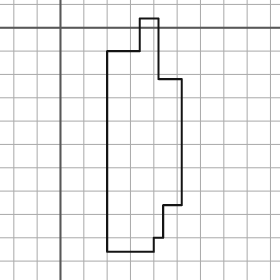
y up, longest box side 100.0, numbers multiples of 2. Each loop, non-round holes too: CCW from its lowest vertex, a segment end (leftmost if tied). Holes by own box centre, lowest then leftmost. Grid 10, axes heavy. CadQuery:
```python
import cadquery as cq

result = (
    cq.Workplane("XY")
    .moveTo(20.0, -96.0)
    .lineTo(40.0, -96.0)
    .lineTo(40.0, -90.0)
    .lineTo(44.0, -90.0)
    .lineTo(44.0, -76.0)
    .lineTo(52.0, -76.0)
    .lineTo(52.0, -22.0)
    .lineTo(42.0, -22.0)
    .lineTo(42.0, 4.0)
    .lineTo(34.0, 4.0)
    .lineTo(34.0, -10.0)
    .lineTo(20.0, -10.0)
    .close()
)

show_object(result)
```